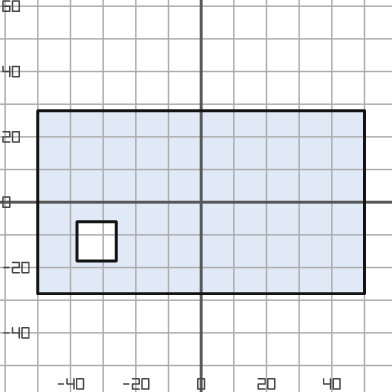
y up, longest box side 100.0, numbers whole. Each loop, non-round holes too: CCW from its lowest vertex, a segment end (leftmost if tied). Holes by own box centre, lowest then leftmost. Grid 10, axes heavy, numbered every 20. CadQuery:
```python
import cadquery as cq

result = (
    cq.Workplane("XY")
    .moveTo(-50.0, -28.0)
    .lineTo(50.0, -28.0)
    .lineTo(50.0, 28.0)
    .lineTo(-50.0, 28.0)
    .close()
    .moveTo(-38.0, -18.0)
    .lineTo(-26.0, -18.0)
    .lineTo(-26.0, -6.0)
    .lineTo(-38.0, -6.0)
    .close()
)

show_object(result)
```